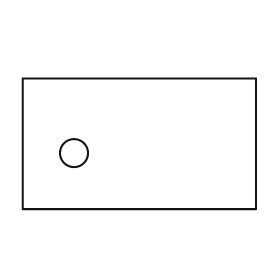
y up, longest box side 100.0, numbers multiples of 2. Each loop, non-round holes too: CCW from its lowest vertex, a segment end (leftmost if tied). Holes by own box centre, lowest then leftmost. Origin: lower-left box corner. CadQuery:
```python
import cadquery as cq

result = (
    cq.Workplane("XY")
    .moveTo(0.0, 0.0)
    .lineTo(100.0, 0.0)
    .lineTo(100.0, 56.0)
    .lineTo(0.0, 56.0)
    .close()
    .moveTo(22.0, 24.0)
    .circle(6.0)
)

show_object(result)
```